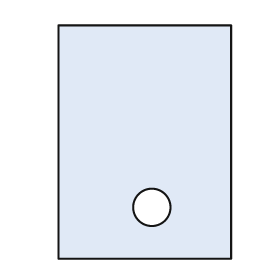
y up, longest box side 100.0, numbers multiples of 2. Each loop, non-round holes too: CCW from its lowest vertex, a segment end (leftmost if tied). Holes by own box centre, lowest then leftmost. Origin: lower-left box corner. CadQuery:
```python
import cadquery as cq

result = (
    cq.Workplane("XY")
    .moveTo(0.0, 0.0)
    .lineTo(74.0, 0.0)
    .lineTo(74.0, 100.0)
    .lineTo(0.0, 100.0)
    .close()
    .moveTo(40.0, 22.0)
    .circle(8.0)
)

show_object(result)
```